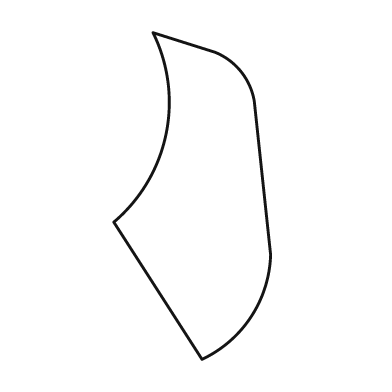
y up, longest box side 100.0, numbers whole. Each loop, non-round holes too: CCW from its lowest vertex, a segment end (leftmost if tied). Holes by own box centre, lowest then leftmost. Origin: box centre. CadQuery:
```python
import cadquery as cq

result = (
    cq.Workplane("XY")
    .moveTo(3.0, -50.0)
    .threePointArc((18.0, -37.0), (24.0, -18.0))
    .lineTo(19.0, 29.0)
    .threePointArc((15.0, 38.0), (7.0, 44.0))
    .lineTo(-12.0, 50.0)
    .threePointArc((-8.0, 19.0), (-24.0, -8.0))
    .close()
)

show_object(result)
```